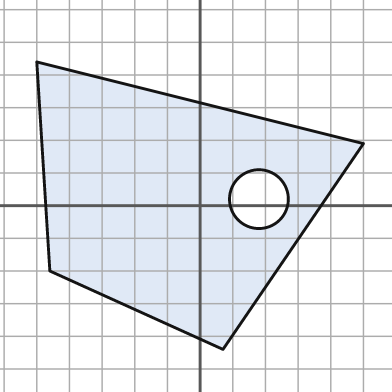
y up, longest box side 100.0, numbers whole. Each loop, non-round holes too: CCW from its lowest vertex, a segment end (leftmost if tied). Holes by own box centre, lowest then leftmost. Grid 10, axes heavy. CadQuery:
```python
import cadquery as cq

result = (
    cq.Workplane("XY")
    .moveTo(7.0, -44.0)
    .lineTo(50.0, 19.0)
    .lineTo(-50.0, 44.0)
    .lineTo(-46.0, -20.0)
    .close()
    .moveTo(18.0, 2.0)
    .circle(9.0)
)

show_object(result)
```